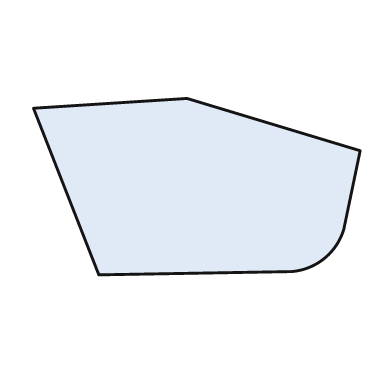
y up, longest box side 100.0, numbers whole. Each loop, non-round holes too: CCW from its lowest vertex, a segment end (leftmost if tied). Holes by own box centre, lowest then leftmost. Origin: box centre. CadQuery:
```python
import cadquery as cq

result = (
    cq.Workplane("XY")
    .moveTo(-30.0, -27.0)
    .lineTo(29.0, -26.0)
    .threePointArc((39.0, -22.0), (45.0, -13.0))
    .lineTo(50.0, 11.0)
    .lineTo(-3.0, 27.0)
    .lineTo(-50.0, 24.0)
    .close()
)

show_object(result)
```